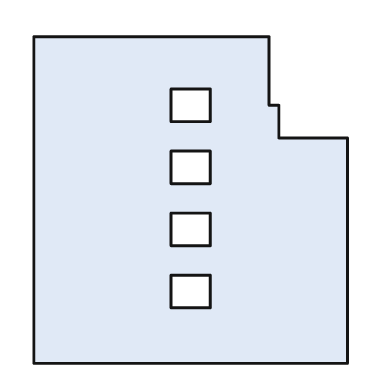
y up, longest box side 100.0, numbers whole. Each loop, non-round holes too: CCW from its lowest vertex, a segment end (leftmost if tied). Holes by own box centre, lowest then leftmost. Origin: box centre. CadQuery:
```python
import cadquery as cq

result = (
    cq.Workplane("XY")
    .moveTo(-48.0, -50.0)
    .lineTo(48.0, -50.0)
    .lineTo(48.0, 19.0)
    .lineTo(27.0, 19.0)
    .lineTo(27.0, 29.0)
    .lineTo(24.0, 29.0)
    .lineTo(24.0, 50.0)
    .lineTo(-48.0, 50.0)
    .close()
    .moveTo(-6.0, -33.0)
    .lineTo(6.0, -33.0)
    .lineTo(6.0, -23.0)
    .lineTo(-6.0, -23.0)
    .close()
    .moveTo(-6.0, -14.0)
    .lineTo(6.0, -14.0)
    .lineTo(6.0, -4.0)
    .lineTo(-6.0, -4.0)
    .close()
    .moveTo(-6.0, 5.0)
    .lineTo(6.0, 5.0)
    .lineTo(6.0, 15.0)
    .lineTo(-6.0, 15.0)
    .close()
    .moveTo(-6.0, 24.0)
    .lineTo(6.0, 24.0)
    .lineTo(6.0, 34.0)
    .lineTo(-6.0, 34.0)
    .close()
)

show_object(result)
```